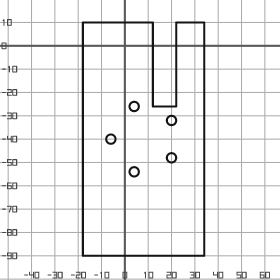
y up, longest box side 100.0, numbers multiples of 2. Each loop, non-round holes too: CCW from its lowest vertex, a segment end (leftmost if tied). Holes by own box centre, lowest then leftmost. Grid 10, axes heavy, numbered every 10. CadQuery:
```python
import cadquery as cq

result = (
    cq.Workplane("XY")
    .moveTo(-18.0, -90.0)
    .lineTo(34.0, -90.0)
    .lineTo(34.0, 10.0)
    .lineTo(22.0, 10.0)
    .lineTo(22.0, -26.0)
    .lineTo(12.0, -26.0)
    .lineTo(12.0, 10.0)
    .lineTo(-18.0, 10.0)
    .close()
    .moveTo(4.0, -54.0)
    .circle(2.0)
    .moveTo(20.0, -48.0)
    .circle(2.0)
    .moveTo(-6.0, -40.0)
    .circle(2.0)
    .moveTo(20.0, -32.0)
    .circle(2.0)
    .moveTo(4.0, -26.0)
    .circle(2.0)
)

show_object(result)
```